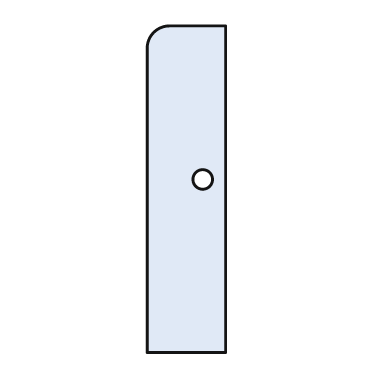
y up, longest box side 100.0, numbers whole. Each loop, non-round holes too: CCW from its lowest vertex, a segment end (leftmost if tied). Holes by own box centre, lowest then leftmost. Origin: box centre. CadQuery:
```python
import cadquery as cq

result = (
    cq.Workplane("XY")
    .moveTo(-12.0, -50.0)
    .lineTo(12.0, -50.0)
    .lineTo(12.0, 50.0)
    .lineTo(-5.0, 50.0)
    .threePointArc((-10.0, 48.0), (-12.0, 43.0))
    .close()
    .moveTo(5.0, 3.0)
    .circle(3.0)
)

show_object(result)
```